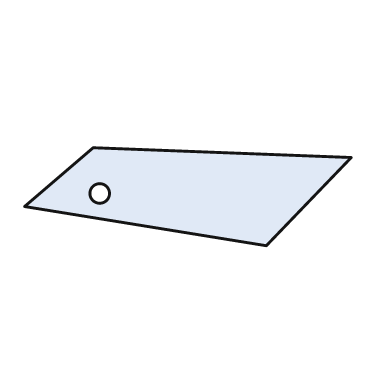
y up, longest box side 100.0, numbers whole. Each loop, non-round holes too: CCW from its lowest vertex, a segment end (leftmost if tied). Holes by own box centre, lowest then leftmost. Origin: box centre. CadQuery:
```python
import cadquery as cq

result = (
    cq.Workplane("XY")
    .moveTo(24.0, -15.0)
    .lineTo(50.0, 12.0)
    .lineTo(-29.0, 15.0)
    .lineTo(-50.0, -3.0)
    .close()
    .moveTo(-27.0, 1.0)
    .circle(3.0)
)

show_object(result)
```